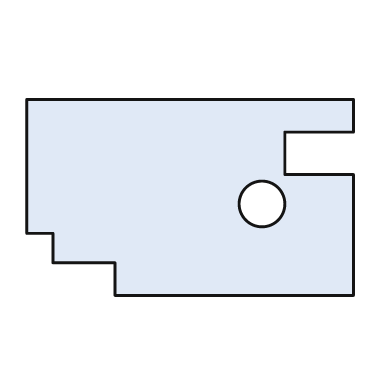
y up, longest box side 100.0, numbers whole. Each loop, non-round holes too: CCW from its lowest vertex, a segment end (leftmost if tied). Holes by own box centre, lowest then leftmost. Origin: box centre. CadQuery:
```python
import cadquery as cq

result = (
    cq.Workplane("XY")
    .moveTo(-23.0, -30.0)
    .lineTo(50.0, -30.0)
    .lineTo(50.0, 7.0)
    .lineTo(29.0, 7.0)
    .lineTo(29.0, 20.0)
    .lineTo(50.0, 20.0)
    .lineTo(50.0, 30.0)
    .lineTo(-50.0, 30.0)
    .lineTo(-50.0, -11.0)
    .lineTo(-42.0, -11.0)
    .lineTo(-42.0, -20.0)
    .lineTo(-23.0, -20.0)
    .close()
    .moveTo(22.0, -2.0)
    .circle(7.0)
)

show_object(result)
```